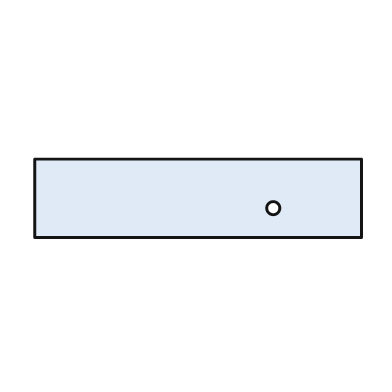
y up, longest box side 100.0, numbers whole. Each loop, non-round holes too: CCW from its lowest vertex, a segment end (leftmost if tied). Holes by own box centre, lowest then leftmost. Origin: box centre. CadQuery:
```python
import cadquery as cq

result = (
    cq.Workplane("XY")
    .moveTo(-50.0, -12.0)
    .lineTo(50.0, -12.0)
    .lineTo(50.0, 12.0)
    .lineTo(-50.0, 12.0)
    .close()
    .moveTo(23.0, -3.0)
    .circle(2.0)
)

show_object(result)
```